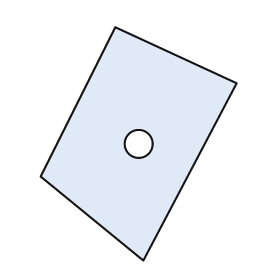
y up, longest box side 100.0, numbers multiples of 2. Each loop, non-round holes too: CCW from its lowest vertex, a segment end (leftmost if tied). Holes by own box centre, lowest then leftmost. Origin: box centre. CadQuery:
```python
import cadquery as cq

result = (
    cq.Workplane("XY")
    .moveTo(2.0, -50.0)
    .lineTo(42.0, 26.0)
    .lineTo(-10.0, 50.0)
    .lineTo(-42.0, -14.0)
    .close()
    .moveTo(0.0, 0.0)
    .circle(6.0)
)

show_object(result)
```